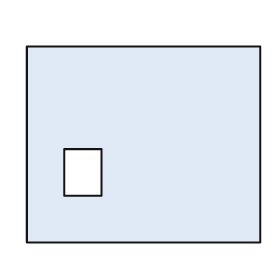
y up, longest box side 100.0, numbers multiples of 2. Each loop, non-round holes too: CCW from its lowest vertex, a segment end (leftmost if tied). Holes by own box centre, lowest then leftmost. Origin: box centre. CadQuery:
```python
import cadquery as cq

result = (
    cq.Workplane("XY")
    .moveTo(-50.0, -42.0)
    .lineTo(50.0, -42.0)
    .lineTo(50.0, 42.0)
    .lineTo(-50.0, 42.0)
    .close()
    .moveTo(-34.0, -22.0)
    .lineTo(-18.0, -22.0)
    .lineTo(-18.0, -2.0)
    .lineTo(-34.0, -2.0)
    .close()
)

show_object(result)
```